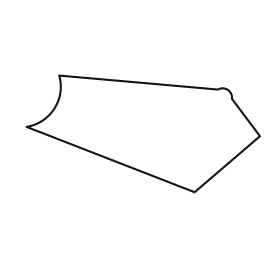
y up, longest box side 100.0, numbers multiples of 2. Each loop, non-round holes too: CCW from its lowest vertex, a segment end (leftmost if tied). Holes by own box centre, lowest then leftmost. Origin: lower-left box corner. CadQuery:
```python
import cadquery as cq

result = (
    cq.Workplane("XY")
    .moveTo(72.0, 0.0)
    .lineTo(100.0, 24.0)
    .lineTo(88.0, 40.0)
    .threePointArc((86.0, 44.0), (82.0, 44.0))
    .lineTo(14.0, 50.0)
    .threePointArc((12.0, 36.0), (0.0, 28.0))
    .close()
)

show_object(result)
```